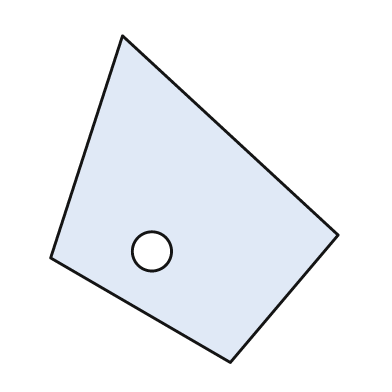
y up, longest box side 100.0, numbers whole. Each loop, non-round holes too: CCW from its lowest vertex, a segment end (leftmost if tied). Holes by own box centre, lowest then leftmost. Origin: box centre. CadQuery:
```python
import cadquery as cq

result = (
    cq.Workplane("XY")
    .moveTo(11.0, -50.0)
    .lineTo(44.0, -11.0)
    .lineTo(-22.0, 50.0)
    .lineTo(-44.0, -18.0)
    .close()
    .moveTo(-13.0, -16.0)
    .circle(6.0)
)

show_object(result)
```